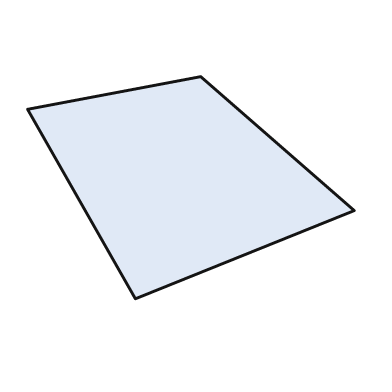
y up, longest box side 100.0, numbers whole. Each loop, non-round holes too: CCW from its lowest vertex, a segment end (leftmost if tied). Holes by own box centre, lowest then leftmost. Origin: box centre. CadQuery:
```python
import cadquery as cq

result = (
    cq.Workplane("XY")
    .moveTo(-17.0, -34.0)
    .lineTo(50.0, -7.0)
    .lineTo(3.0, 34.0)
    .lineTo(-50.0, 24.0)
    .close()
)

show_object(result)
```